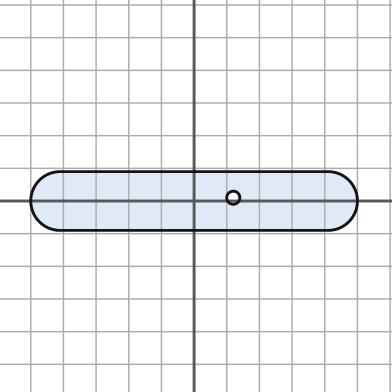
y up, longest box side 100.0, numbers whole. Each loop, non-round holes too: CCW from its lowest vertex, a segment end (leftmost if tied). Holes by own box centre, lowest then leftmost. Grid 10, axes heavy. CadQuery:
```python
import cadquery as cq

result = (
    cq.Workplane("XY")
    .moveTo(-41.0, -9.0)
    .lineTo(41.0, -9.0)
    .threePointArc((50.0, 0.0), (41.0, 9.0))
    .lineTo(-41.0, 9.0)
    .threePointArc((-50.0, 0.0), (-41.0, -9.0))
    .close()
    .moveTo(12.0, 1.0)
    .circle(2.0)
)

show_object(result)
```